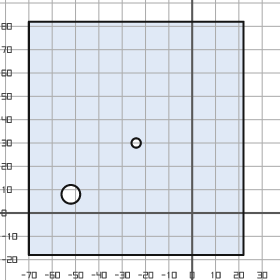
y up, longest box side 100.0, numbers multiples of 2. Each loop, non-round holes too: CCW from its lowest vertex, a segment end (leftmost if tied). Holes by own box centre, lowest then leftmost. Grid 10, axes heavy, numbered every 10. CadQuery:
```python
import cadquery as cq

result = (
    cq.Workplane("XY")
    .moveTo(-70.0, -18.0)
    .lineTo(22.0, -18.0)
    .lineTo(22.0, 82.0)
    .lineTo(-70.0, 82.0)
    .close()
    .moveTo(-52.0, 8.0)
    .circle(4.0)
    .moveTo(-24.0, 30.0)
    .circle(2.0)
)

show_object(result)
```